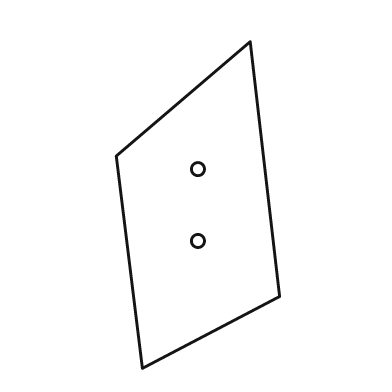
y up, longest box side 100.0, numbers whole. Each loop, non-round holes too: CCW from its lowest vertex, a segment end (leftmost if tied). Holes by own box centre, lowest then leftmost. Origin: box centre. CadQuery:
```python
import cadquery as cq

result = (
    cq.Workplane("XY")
    .moveTo(-17.0, -50.0)
    .lineTo(25.0, -28.0)
    .lineTo(16.0, 50.0)
    .lineTo(-25.0, 15.0)
    .close()
    .moveTo(0.0, -11.0)
    .circle(2.0)
    .moveTo(0.0, 11.0)
    .circle(2.0)
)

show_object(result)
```